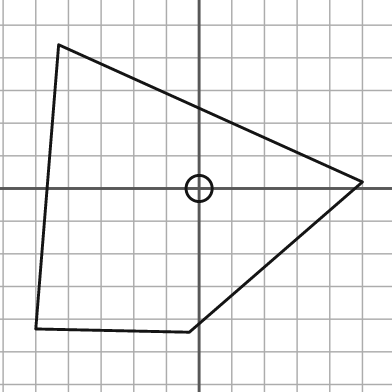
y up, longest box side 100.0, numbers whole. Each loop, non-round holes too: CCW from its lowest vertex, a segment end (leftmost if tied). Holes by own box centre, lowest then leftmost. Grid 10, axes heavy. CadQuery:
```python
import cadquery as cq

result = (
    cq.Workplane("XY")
    .moveTo(-3.0, -44.0)
    .lineTo(50.0, 2.0)
    .lineTo(-43.0, 44.0)
    .lineTo(-50.0, -43.0)
    .close()
    .moveTo(0.0, 0.0)
    .circle(4.0)
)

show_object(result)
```